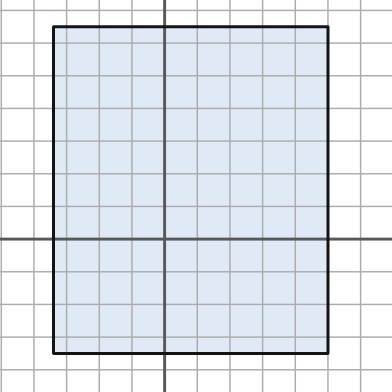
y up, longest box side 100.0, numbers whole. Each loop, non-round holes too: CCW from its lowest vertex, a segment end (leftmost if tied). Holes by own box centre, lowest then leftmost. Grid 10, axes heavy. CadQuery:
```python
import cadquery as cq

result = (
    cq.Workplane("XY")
    .moveTo(-34.0, -35.0)
    .lineTo(50.0, -35.0)
    .lineTo(50.0, 65.0)
    .lineTo(-34.0, 65.0)
    .close()
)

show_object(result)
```